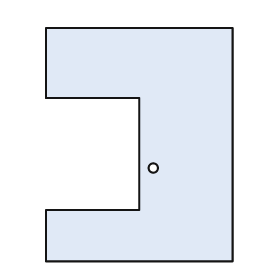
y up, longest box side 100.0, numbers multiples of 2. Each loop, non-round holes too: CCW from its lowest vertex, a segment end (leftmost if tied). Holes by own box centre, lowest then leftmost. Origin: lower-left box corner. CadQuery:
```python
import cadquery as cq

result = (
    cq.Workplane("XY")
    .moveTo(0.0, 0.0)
    .lineTo(80.0, 0.0)
    .lineTo(80.0, 100.0)
    .lineTo(0.0, 100.0)
    .lineTo(0.0, 70.0)
    .lineTo(40.0, 70.0)
    .lineTo(40.0, 22.0)
    .lineTo(0.0, 22.0)
    .close()
    .moveTo(46.0, 40.0)
    .circle(2.0)
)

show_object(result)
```